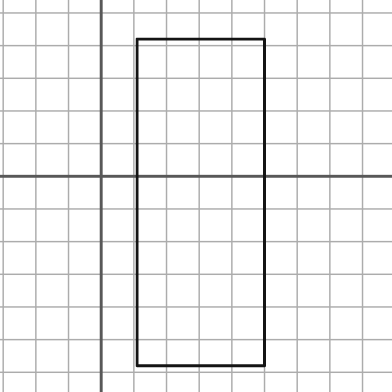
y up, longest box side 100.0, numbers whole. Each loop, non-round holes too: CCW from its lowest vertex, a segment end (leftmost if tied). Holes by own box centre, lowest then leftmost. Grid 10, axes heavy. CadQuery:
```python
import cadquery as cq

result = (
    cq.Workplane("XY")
    .moveTo(11.0, -58.0)
    .lineTo(50.0, -58.0)
    .lineTo(50.0, 42.0)
    .lineTo(11.0, 42.0)
    .close()
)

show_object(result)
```